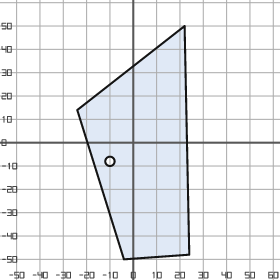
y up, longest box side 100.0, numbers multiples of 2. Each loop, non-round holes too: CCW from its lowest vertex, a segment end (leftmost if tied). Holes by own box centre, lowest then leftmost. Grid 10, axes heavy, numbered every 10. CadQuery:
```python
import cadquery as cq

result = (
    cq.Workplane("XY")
    .moveTo(-4.0, -50.0)
    .lineTo(24.0, -48.0)
    .lineTo(22.0, 50.0)
    .lineTo(-24.0, 14.0)
    .close()
    .moveTo(-10.0, -8.0)
    .circle(2.0)
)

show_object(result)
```